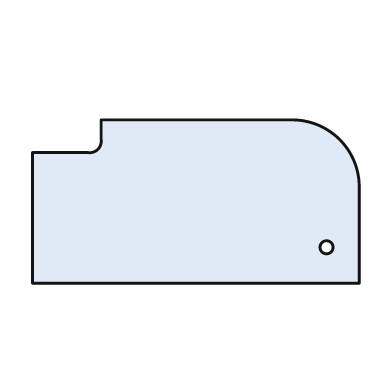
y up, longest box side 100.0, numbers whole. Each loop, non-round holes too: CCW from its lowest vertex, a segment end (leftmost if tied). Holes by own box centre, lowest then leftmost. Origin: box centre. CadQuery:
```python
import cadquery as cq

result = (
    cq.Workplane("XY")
    .moveTo(-50.0, -25.0)
    .lineTo(50.0, -25.0)
    .lineTo(50.0, 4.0)
    .threePointArc((44.0, 19.0), (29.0, 25.0))
    .lineTo(-29.0, 25.0)
    .lineTo(-29.0, 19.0)
    .threePointArc((-30.0, 16.0), (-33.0, 15.0))
    .lineTo(-50.0, 15.0)
    .close()
    .moveTo(40.0, -14.0)
    .circle(2.0)
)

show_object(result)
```